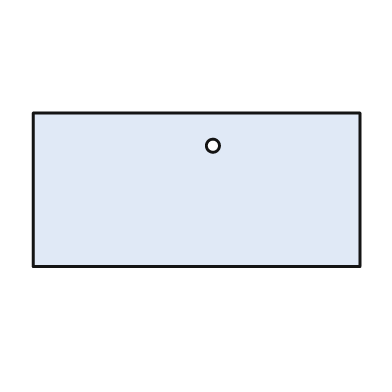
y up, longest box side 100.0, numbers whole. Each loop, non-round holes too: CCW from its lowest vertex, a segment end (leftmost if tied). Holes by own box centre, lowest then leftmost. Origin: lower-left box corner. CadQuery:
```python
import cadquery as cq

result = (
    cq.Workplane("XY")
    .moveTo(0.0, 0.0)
    .lineTo(100.0, 0.0)
    .lineTo(100.0, 47.0)
    .lineTo(0.0, 47.0)
    .close()
    .moveTo(55.0, 37.0)
    .circle(2.0)
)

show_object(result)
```